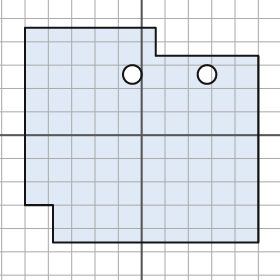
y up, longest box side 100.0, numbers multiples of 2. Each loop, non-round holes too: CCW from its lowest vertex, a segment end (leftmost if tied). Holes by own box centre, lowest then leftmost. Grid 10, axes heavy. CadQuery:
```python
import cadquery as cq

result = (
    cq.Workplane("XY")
    .moveTo(-38.0, -46.0)
    .lineTo(50.0, -46.0)
    .lineTo(50.0, 34.0)
    .lineTo(6.0, 34.0)
    .lineTo(6.0, 46.0)
    .lineTo(-50.0, 46.0)
    .lineTo(-50.0, -30.0)
    .lineTo(-38.0, -30.0)
    .close()
    .moveTo(-4.0, 26.0)
    .circle(4.0)
    .moveTo(28.0, 26.0)
    .circle(4.0)
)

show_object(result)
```